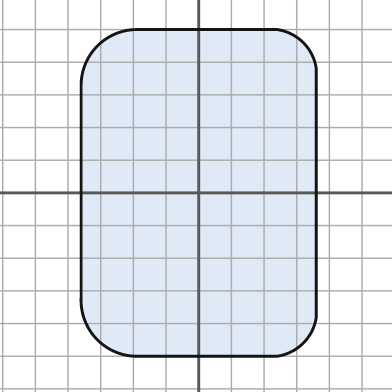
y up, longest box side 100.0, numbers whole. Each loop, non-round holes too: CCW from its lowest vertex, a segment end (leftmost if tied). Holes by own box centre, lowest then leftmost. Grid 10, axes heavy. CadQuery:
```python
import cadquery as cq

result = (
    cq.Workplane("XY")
    .moveTo(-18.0, -50.0)
    .lineTo(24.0, -50.0)
    .threePointArc((32.0, -46.0), (36.0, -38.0))
    .lineTo(36.0, 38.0)
    .threePointArc((32.0, 46.0), (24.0, 50.0))
    .lineTo(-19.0, 50.0)
    .threePointArc((-31.0, 45.0), (-36.0, 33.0))
    .lineTo(-36.0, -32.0)
    .threePointArc((-31.0, -45.0), (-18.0, -50.0))
    .close()
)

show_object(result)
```